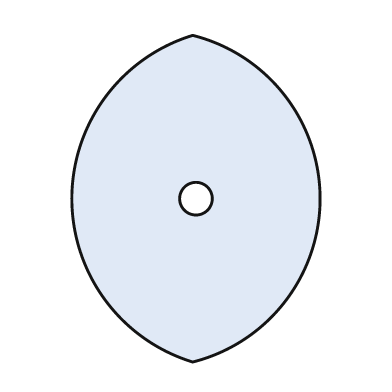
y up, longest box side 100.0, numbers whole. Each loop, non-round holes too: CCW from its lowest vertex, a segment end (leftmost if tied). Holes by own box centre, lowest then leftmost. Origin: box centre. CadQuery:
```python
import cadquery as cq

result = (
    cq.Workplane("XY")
    .moveTo(-1.0, -50.0)
    .threePointArc((38.0, 0.0), (-1.0, 50.0))
    .threePointArc((-38.0, 0.0), (-1.0, -50.0))
    .close()
    .moveTo(0.0, 0.0)
    .circle(5.0)
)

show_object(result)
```